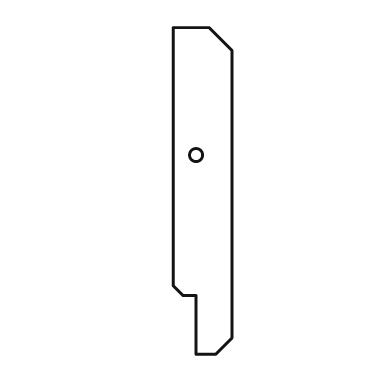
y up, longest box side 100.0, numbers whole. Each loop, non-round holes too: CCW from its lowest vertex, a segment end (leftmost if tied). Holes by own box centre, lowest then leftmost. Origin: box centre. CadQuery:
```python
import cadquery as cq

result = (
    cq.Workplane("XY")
    .moveTo(-2.0, -50.0)
    .lineTo(4.0, -50.0)
    .lineTo(9.0, -45.0)
    .lineTo(9.0, 43.0)
    .lineTo(2.0, 50.0)
    .lineTo(-9.0, 50.0)
    .lineTo(-9.0, -29.0)
    .lineTo(-6.0, -32.0)
    .lineTo(-2.0, -32.0)
    .close()
    .moveTo(-2.0, 11.0)
    .circle(2.0)
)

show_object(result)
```